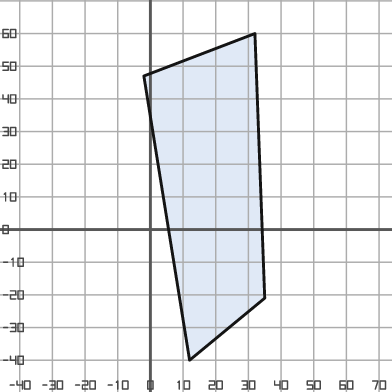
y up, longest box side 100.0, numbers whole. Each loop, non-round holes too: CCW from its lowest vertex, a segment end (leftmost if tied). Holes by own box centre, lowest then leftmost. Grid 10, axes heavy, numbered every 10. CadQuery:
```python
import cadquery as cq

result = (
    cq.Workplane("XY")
    .moveTo(12.0, -40.0)
    .lineTo(35.0, -21.0)
    .lineTo(32.0, 60.0)
    .lineTo(-2.0, 47.0)
    .close()
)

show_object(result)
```